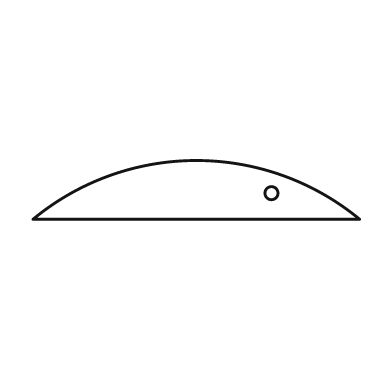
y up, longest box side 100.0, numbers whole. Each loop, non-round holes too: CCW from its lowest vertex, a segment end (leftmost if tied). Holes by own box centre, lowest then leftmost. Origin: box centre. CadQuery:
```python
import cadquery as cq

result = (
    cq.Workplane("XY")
    .moveTo(-50.0, -9.0)
    .lineTo(50.0, -9.0)
    .threePointArc((0.0, 9.0), (-50.0, -9.0))
    .close()
    .moveTo(23.0, -1.0)
    .circle(2.0)
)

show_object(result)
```